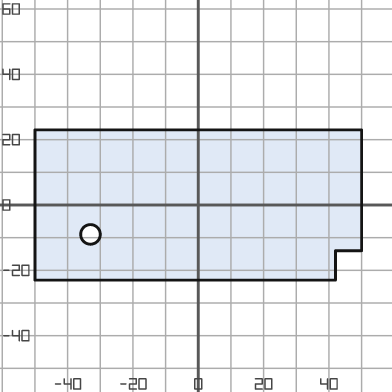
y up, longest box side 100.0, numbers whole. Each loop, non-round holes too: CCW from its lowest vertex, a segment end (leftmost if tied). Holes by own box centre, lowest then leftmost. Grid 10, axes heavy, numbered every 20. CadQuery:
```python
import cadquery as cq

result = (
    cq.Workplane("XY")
    .moveTo(-50.0, -23.0)
    .lineTo(42.0, -23.0)
    .lineTo(42.0, -14.0)
    .lineTo(50.0, -14.0)
    .lineTo(50.0, 23.0)
    .lineTo(-50.0, 23.0)
    .close()
    .moveTo(-33.0, -9.0)
    .circle(3.0)
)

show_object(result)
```